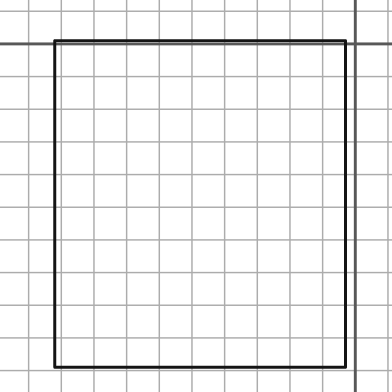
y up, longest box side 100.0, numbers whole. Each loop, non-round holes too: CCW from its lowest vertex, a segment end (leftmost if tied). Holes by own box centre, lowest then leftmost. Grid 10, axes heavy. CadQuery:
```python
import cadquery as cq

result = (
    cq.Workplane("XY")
    .moveTo(-92.0, -99.0)
    .lineTo(-3.0, -99.0)
    .lineTo(-3.0, 1.0)
    .lineTo(-92.0, 1.0)
    .close()
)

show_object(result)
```